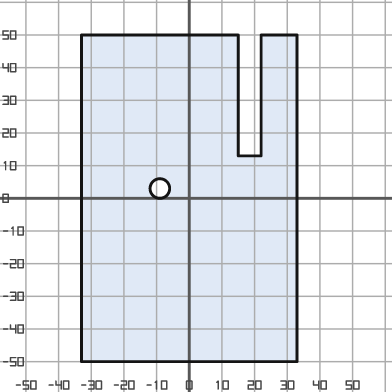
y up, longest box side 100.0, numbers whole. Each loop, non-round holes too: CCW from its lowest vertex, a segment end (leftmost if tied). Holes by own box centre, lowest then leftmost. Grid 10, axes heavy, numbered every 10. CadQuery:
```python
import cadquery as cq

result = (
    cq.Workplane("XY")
    .moveTo(-33.0, -50.0)
    .lineTo(33.0, -50.0)
    .lineTo(33.0, 50.0)
    .lineTo(22.0, 50.0)
    .lineTo(22.0, 13.0)
    .lineTo(15.0, 13.0)
    .lineTo(15.0, 50.0)
    .lineTo(-33.0, 50.0)
    .close()
    .moveTo(-9.0, 3.0)
    .circle(3.0)
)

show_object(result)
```